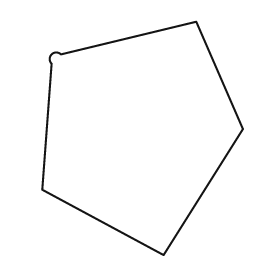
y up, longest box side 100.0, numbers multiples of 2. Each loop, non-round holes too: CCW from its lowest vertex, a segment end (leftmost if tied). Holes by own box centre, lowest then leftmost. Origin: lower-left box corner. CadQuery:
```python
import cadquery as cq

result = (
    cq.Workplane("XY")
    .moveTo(52.0, 0.0)
    .lineTo(86.0, 54.0)
    .lineTo(66.0, 100.0)
    .lineTo(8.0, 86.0)
    .threePointArc((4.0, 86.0), (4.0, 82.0))
    .lineTo(0.0, 28.0)
    .close()
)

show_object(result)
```